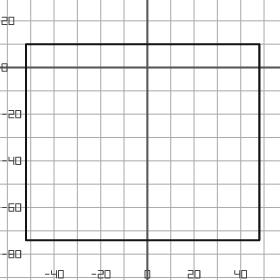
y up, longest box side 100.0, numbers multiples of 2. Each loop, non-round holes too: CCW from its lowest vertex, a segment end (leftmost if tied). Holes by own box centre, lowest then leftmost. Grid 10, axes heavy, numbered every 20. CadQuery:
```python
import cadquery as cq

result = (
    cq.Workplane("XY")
    .moveTo(-52.0, -74.0)
    .lineTo(48.0, -74.0)
    .lineTo(48.0, 10.0)
    .lineTo(-52.0, 10.0)
    .close()
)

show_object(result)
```